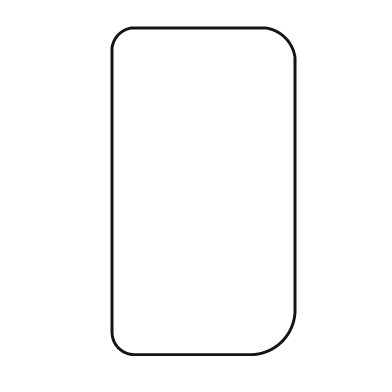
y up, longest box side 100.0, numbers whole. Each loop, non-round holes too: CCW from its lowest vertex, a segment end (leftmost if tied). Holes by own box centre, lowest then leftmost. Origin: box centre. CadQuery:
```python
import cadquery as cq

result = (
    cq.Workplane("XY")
    .moveTo(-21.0, -50.0)
    .lineTo(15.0, -50.0)
    .threePointArc((24.0, -46.0), (28.0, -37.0))
    .lineTo(28.0, 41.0)
    .threePointArc((25.0, 47.0), (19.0, 50.0))
    .lineTo(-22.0, 50.0)
    .threePointArc((-26.0, 48.0), (-28.0, 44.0))
    .lineTo(-28.0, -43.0)
    .threePointArc((-26.0, -48.0), (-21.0, -50.0))
    .close()
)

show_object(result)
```